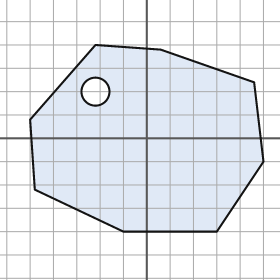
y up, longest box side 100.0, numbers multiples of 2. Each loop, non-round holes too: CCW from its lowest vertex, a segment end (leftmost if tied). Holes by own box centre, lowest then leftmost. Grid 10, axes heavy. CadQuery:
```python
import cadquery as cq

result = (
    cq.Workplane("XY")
    .moveTo(-10.0, -40.0)
    .lineTo(30.0, -40.0)
    .lineTo(50.0, -10.0)
    .lineTo(46.0, 24.0)
    .lineTo(6.0, 38.0)
    .lineTo(-22.0, 40.0)
    .lineTo(-50.0, 8.0)
    .lineTo(-48.0, -22.0)
    .close()
    .moveTo(-22.0, 20.0)
    .circle(6.0)
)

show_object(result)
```